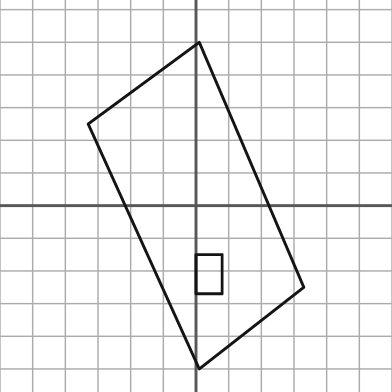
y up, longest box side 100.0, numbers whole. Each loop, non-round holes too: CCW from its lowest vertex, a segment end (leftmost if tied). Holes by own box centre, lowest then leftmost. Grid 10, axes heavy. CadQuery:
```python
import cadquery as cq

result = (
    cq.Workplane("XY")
    .moveTo(1.0, -50.0)
    .lineTo(33.0, -25.0)
    .lineTo(1.0, 50.0)
    .lineTo(-33.0, 25.0)
    .close()
    .moveTo(0.0, -27.0)
    .lineTo(8.0, -27.0)
    .lineTo(8.0, -15.0)
    .lineTo(0.0, -15.0)
    .close()
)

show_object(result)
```